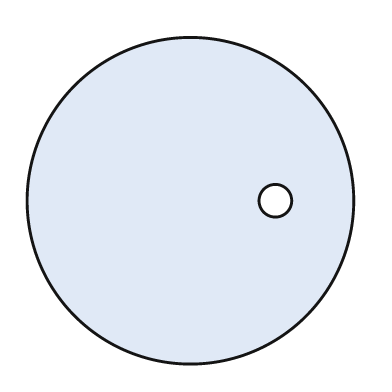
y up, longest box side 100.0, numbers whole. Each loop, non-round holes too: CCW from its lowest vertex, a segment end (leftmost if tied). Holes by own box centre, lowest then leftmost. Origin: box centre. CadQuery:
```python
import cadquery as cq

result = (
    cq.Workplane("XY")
    .moveTo(0.0, 0.0)
    .circle(50.0)
    .moveTo(26.0, 0.0)
    .circle(5.0)
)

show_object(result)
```